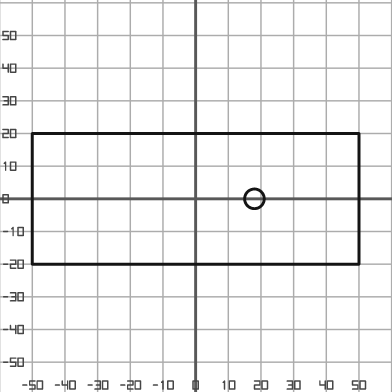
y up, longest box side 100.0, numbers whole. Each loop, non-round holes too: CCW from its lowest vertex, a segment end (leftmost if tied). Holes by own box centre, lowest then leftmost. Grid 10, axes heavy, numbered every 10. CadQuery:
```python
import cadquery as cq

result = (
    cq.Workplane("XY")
    .moveTo(-50.0, -20.0)
    .lineTo(50.0, -20.0)
    .lineTo(50.0, 20.0)
    .lineTo(-50.0, 20.0)
    .close()
    .moveTo(18.0, 0.0)
    .circle(3.0)
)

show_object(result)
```